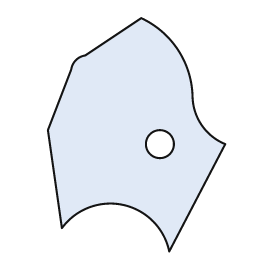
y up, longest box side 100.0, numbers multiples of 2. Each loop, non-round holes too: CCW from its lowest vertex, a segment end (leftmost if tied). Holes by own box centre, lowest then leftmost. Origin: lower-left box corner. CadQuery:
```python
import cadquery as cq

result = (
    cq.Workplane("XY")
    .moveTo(52.0, 0.0)
    .lineTo(76.0, 46.0)
    .threePointArc((66.0, 54.0), (62.0, 66.0))
    .threePointArc((56.0, 86.0), (40.0, 100.0))
    .lineTo(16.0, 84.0)
    .threePointArc((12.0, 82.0), (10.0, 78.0))
    .lineTo(0.0, 52.0)
    .lineTo(6.0, 10.0)
    .threePointArc((32.0, 20.0), (52.0, 0.0))
    .close()
    .moveTo(48.0, 46.0)
    .circle(6.0)
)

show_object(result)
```